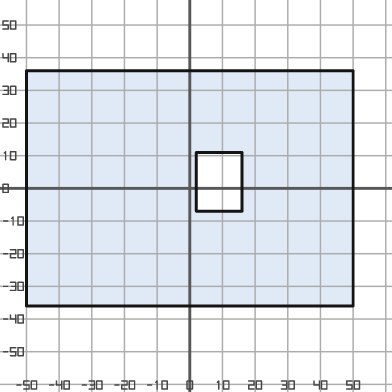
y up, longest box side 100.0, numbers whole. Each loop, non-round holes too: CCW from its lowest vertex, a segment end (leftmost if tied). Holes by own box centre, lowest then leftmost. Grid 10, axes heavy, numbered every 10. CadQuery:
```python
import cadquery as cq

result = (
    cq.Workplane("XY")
    .moveTo(-50.0, -36.0)
    .lineTo(50.0, -36.0)
    .lineTo(50.0, 36.0)
    .lineTo(-50.0, 36.0)
    .close()
    .moveTo(2.0, -7.0)
    .lineTo(16.0, -7.0)
    .lineTo(16.0, 11.0)
    .lineTo(2.0, 11.0)
    .close()
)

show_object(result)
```